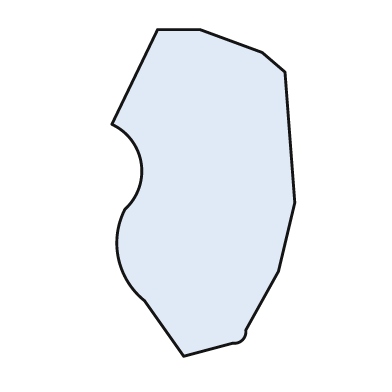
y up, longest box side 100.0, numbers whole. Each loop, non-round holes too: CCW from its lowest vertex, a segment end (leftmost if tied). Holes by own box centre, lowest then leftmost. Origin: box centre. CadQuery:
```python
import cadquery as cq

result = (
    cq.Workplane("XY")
    .moveTo(-6.0, -50.0)
    .lineTo(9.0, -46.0)
    .threePointArc((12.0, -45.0), (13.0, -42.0))
    .lineTo(23.0, -24.0)
    .lineTo(28.0, -3.0)
    .lineTo(25.0, 37.0)
    .lineTo(18.0, 43.0)
    .lineTo(-1.0, 50.0)
    .lineTo(-14.0, 50.0)
    .lineTo(-28.0, 21.0)
    .threePointArc((-19.0, 9.0), (-24.0, -5.0))
    .threePointArc((-26.0, -20.0), (-18.0, -33.0))
    .close()
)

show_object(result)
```